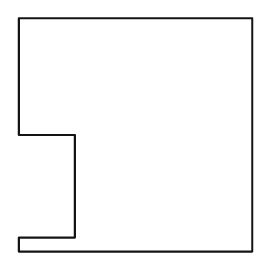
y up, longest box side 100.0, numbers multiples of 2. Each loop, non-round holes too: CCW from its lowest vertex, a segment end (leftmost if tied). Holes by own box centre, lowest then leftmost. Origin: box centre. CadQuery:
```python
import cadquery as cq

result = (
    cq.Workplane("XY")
    .moveTo(-50.0, -50.0)
    .lineTo(50.0, -50.0)
    .lineTo(50.0, 50.0)
    .lineTo(-50.0, 50.0)
    .lineTo(-50.0, 0.0)
    .lineTo(-26.0, 0.0)
    .lineTo(-26.0, -44.0)
    .lineTo(-50.0, -44.0)
    .close()
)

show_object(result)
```